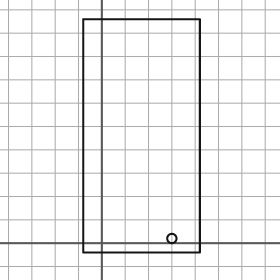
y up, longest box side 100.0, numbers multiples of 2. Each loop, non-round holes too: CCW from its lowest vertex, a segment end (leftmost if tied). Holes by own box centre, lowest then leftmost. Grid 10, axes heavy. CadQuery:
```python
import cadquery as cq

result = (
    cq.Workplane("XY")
    .moveTo(-8.0, -4.0)
    .lineTo(42.0, -4.0)
    .lineTo(42.0, 96.0)
    .lineTo(-8.0, 96.0)
    .close()
    .moveTo(30.0, 2.0)
    .circle(2.0)
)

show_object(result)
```